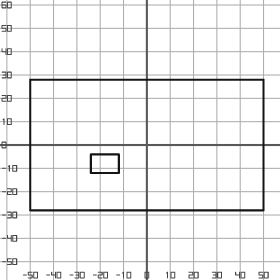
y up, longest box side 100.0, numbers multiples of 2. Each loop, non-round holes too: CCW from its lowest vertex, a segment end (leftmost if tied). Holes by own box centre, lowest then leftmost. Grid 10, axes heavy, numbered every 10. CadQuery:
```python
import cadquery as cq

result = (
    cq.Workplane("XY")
    .moveTo(-50.0, -28.0)
    .lineTo(50.0, -28.0)
    .lineTo(50.0, 28.0)
    .lineTo(-50.0, 28.0)
    .close()
    .moveTo(-24.0, -12.0)
    .lineTo(-12.0, -12.0)
    .lineTo(-12.0, -4.0)
    .lineTo(-24.0, -4.0)
    .close()
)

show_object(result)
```